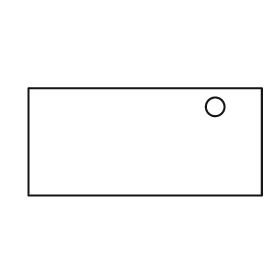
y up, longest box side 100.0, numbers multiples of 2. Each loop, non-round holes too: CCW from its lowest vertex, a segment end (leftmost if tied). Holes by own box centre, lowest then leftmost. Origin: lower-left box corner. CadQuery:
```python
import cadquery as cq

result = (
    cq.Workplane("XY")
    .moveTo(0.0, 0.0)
    .lineTo(100.0, 0.0)
    .lineTo(100.0, 46.0)
    .lineTo(0.0, 46.0)
    .close()
    .moveTo(80.0, 38.0)
    .circle(4.0)
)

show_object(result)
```